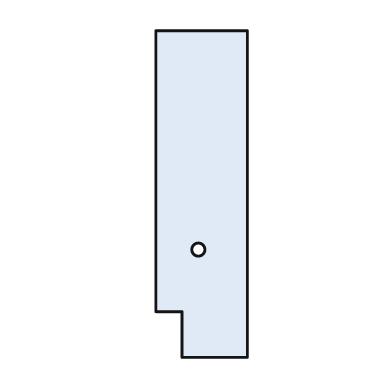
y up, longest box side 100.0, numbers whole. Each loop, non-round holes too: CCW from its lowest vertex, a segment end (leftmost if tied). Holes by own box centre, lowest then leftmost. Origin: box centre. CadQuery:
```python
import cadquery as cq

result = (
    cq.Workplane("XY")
    .moveTo(-6.0, -50.0)
    .lineTo(14.0, -50.0)
    .lineTo(14.0, 50.0)
    .lineTo(-14.0, 50.0)
    .lineTo(-14.0, -36.0)
    .lineTo(-6.0, -36.0)
    .close()
    .moveTo(-1.0, -17.0)
    .circle(2.0)
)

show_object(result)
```